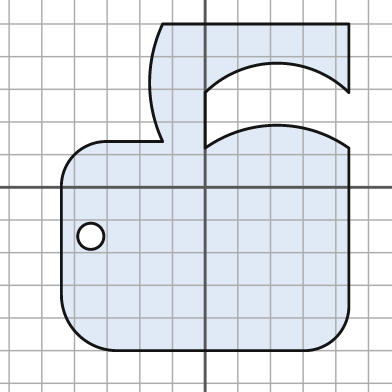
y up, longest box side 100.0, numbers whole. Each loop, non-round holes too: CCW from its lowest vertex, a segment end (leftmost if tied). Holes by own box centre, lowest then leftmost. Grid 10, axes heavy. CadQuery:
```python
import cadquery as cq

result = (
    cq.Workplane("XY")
    .moveTo(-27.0, -50.0)
    .lineTo(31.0, -50.0)
    .threePointArc((40.0, -46.0), (44.0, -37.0))
    .lineTo(44.0, 12.0)
    .threePointArc((22.0, 19.0), (0.0, 12.0))
    .lineTo(0.0, 29.0)
    .threePointArc((22.0, 38.0), (44.0, 29.0))
    .lineTo(44.0, 50.0)
    .lineTo(-13.0, 50.0)
    .threePointArc((-17.0, 32.0), (-13.0, 14.0))
    .lineTo(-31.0, 14.0)
    .threePointArc((-40.0, 10.0), (-44.0, 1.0))
    .lineTo(-44.0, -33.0)
    .threePointArc((-39.0, -45.0), (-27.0, -50.0))
    .close()
    .moveTo(-35.0, -15.0)
    .circle(4.0)
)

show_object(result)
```